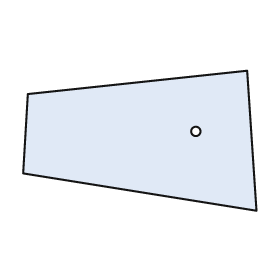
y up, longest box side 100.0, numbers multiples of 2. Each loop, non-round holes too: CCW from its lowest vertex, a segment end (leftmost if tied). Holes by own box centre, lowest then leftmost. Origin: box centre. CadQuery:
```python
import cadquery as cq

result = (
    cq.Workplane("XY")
    .moveTo(50.0, -30.0)
    .lineTo(46.0, 30.0)
    .lineTo(-48.0, 20.0)
    .lineTo(-50.0, -14.0)
    .close()
    .moveTo(24.0, 4.0)
    .circle(2.0)
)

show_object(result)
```